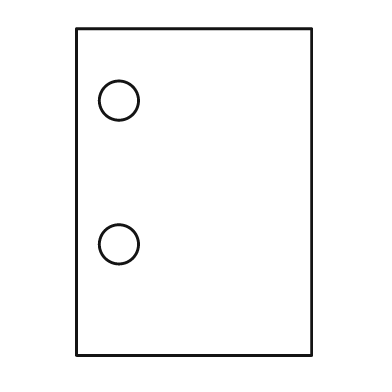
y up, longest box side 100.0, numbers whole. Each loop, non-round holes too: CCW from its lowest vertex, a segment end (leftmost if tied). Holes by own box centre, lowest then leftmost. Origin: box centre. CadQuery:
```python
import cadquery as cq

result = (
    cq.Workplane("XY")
    .moveTo(-36.0, -50.0)
    .lineTo(36.0, -50.0)
    .lineTo(36.0, 50.0)
    .lineTo(-36.0, 50.0)
    .close()
    .moveTo(-23.0, -16.0)
    .circle(6.0)
    .moveTo(-23.0, 28.0)
    .circle(6.0)
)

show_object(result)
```